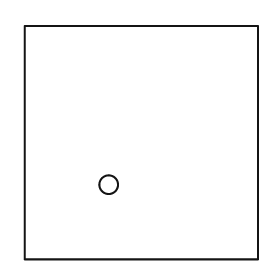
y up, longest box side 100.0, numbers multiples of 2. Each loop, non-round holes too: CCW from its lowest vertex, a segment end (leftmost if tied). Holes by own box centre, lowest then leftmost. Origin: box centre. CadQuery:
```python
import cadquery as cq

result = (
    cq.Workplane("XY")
    .moveTo(-50.0, -50.0)
    .lineTo(50.0, -50.0)
    .lineTo(50.0, 50.0)
    .lineTo(-50.0, 50.0)
    .close()
    .moveTo(-14.0, -18.0)
    .circle(4.0)
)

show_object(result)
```